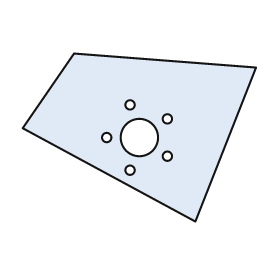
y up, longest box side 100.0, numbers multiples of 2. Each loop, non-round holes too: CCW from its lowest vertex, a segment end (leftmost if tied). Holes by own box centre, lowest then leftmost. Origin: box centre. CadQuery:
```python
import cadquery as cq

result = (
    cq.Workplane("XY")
    .moveTo(24.0, -36.0)
    .lineTo(50.0, 30.0)
    .lineTo(-28.0, 36.0)
    .lineTo(-50.0, 4.0)
    .close()
    .moveTo(-4.0, -14.0)
    .circle(2.0)
    .moveTo(12.0, -8.0)
    .circle(2.0)
    .moveTo(-14.0, 0.0)
    .circle(2.0)
    .moveTo(0.0, 0.0)
    .circle(8.0)
    .moveTo(12.0, 8.0)
    .circle(2.0)
    .moveTo(-4.0, 14.0)
    .circle(2.0)
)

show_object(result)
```